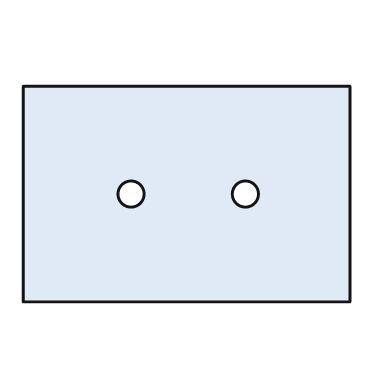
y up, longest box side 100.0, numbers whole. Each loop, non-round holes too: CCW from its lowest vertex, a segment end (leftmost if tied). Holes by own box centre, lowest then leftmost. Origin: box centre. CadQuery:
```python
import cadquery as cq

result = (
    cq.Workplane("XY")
    .moveTo(-50.0, -33.0)
    .lineTo(50.0, -33.0)
    .lineTo(50.0, 33.0)
    .lineTo(-50.0, 33.0)
    .close()
    .moveTo(-17.0, 0.0)
    .circle(4.0)
    .moveTo(18.0, 0.0)
    .circle(4.0)
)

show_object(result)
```